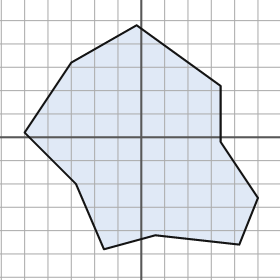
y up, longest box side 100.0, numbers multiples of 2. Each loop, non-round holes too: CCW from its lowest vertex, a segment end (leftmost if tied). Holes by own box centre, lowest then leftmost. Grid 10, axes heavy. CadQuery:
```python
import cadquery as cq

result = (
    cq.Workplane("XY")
    .moveTo(-16.0, -48.0)
    .lineTo(6.0, -42.0)
    .lineTo(42.0, -46.0)
    .lineTo(50.0, -26.0)
    .lineTo(34.0, -2.0)
    .lineTo(34.0, 22.0)
    .lineTo(-2.0, 48.0)
    .lineTo(-30.0, 32.0)
    .lineTo(-50.0, 2.0)
    .lineTo(-28.0, -20.0)
    .close()
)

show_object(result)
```